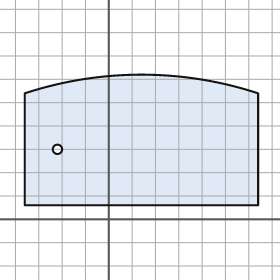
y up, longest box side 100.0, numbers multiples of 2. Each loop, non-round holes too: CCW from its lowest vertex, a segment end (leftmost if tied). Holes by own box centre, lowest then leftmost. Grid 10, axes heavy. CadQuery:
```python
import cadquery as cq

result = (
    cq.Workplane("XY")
    .moveTo(-36.0, 6.0)
    .lineTo(64.0, 6.0)
    .lineTo(64.0, 54.0)
    .threePointArc((14.0, 62.0), (-36.0, 54.0))
    .close()
    .moveTo(-22.0, 30.0)
    .circle(2.0)
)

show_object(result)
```